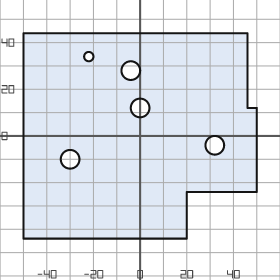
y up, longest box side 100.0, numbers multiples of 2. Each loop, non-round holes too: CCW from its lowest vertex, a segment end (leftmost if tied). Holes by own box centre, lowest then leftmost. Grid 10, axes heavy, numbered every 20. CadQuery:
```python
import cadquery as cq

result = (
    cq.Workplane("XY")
    .moveTo(-50.0, -44.0)
    .lineTo(20.0, -44.0)
    .lineTo(20.0, -24.0)
    .lineTo(50.0, -24.0)
    .lineTo(50.0, 12.0)
    .lineTo(46.0, 12.0)
    .lineTo(46.0, 44.0)
    .lineTo(-50.0, 44.0)
    .close()
    .moveTo(-30.0, -10.0)
    .circle(4.0)
    .moveTo(32.0, -4.0)
    .circle(4.0)
    .moveTo(0.0, 12.0)
    .circle(4.0)
    .moveTo(-4.0, 28.0)
    .circle(4.0)
    .moveTo(-22.0, 34.0)
    .circle(2.0)
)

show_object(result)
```